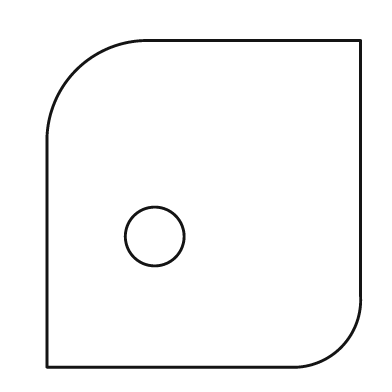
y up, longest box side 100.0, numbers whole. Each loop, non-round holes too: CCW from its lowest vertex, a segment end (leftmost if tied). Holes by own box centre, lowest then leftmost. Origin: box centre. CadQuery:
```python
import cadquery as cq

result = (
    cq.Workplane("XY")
    .moveTo(-48.0, -50.0)
    .lineTo(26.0, -50.0)
    .threePointArc((42.0, -44.0), (48.0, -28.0))
    .lineTo(48.0, 50.0)
    .lineTo(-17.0, 50.0)
    .threePointArc((-39.0, 41.0), (-48.0, 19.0))
    .close()
    .moveTo(-15.0, -10.0)
    .circle(9.0)
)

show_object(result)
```